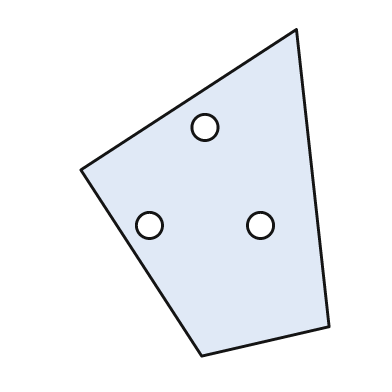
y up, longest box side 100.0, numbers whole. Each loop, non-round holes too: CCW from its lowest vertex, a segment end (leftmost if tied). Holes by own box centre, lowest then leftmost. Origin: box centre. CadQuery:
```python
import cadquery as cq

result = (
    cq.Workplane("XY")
    .moveTo(-1.0, -50.0)
    .lineTo(38.0, -41.0)
    .lineTo(28.0, 50.0)
    .lineTo(-38.0, 7.0)
    .close()
    .moveTo(-17.0, -10.0)
    .circle(4.0)
    .moveTo(17.0, -10.0)
    .circle(4.0)
    .moveTo(0.0, 20.0)
    .circle(4.0)
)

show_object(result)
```